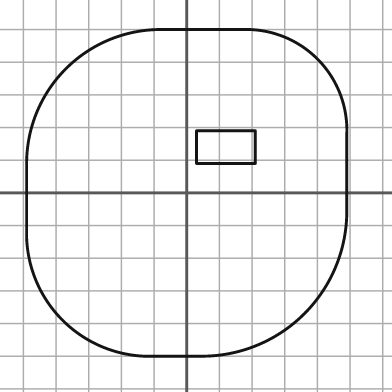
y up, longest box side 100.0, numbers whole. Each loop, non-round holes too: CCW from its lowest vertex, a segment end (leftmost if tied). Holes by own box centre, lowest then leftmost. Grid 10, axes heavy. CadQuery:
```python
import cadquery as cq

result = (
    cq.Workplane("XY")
    .moveTo(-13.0, -50.0)
    .lineTo(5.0, -50.0)
    .threePointArc((36.0, -37.0), (49.0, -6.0))
    .lineTo(49.0, 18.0)
    .threePointArc((40.0, 41.0), (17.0, 50.0))
    .lineTo(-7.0, 50.0)
    .threePointArc((-37.0, 38.0), (-49.0, 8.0))
    .lineTo(-49.0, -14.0)
    .threePointArc((-38.0, -39.0), (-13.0, -50.0))
    .close()
    .moveTo(3.0, 9.0)
    .lineTo(21.0, 9.0)
    .lineTo(21.0, 19.0)
    .lineTo(3.0, 19.0)
    .close()
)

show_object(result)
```